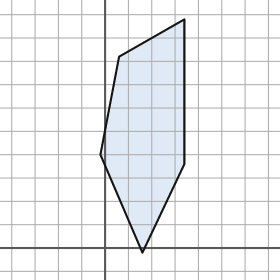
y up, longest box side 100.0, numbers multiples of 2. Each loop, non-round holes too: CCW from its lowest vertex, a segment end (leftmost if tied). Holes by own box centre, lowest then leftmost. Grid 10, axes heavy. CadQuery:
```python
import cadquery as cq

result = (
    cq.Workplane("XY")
    .moveTo(16.0, -2.0)
    .lineTo(34.0, 36.0)
    .lineTo(34.0, 98.0)
    .lineTo(6.0, 82.0)
    .lineTo(-2.0, 40.0)
    .close()
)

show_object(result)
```